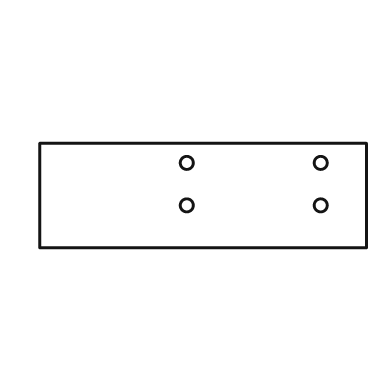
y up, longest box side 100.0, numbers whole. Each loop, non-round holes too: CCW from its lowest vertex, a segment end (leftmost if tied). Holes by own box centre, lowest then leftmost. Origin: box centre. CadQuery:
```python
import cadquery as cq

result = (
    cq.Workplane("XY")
    .moveTo(-50.0, -16.0)
    .lineTo(50.0, -16.0)
    .lineTo(50.0, 16.0)
    .lineTo(-50.0, 16.0)
    .close()
    .moveTo(-5.0, -3.0)
    .circle(2.0)
    .moveTo(36.0, -3.0)
    .circle(2.0)
    .moveTo(-5.0, 10.0)
    .circle(2.0)
    .moveTo(36.0, 10.0)
    .circle(2.0)
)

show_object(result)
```